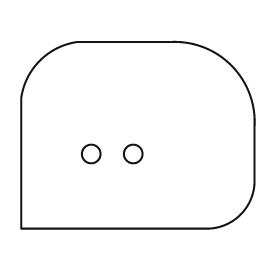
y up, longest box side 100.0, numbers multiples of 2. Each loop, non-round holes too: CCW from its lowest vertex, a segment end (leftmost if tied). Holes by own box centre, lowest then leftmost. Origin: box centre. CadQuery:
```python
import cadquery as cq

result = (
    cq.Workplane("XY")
    .moveTo(-50.0, -40.0)
    .lineTo(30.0, -40.0)
    .threePointArc((44.0, -34.0), (50.0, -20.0))
    .lineTo(50.0, 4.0)
    .threePointArc((40.0, 30.0), (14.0, 40.0))
    .lineTo(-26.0, 40.0)
    .threePointArc((-42.0, 32.0), (-50.0, 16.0))
    .close()
    .moveTo(-20.0, -8.0)
    .circle(4.0)
    .moveTo(-2.0, -8.0)
    .circle(4.0)
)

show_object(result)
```